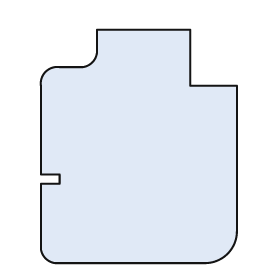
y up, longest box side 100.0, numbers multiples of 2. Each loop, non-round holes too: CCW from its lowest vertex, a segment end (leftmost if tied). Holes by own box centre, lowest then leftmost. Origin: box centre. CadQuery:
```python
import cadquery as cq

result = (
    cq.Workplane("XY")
    .moveTo(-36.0, -50.0)
    .lineTo(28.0, -50.0)
    .threePointArc((38.0, -46.0), (42.0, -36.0))
    .lineTo(42.0, 26.0)
    .lineTo(22.0, 26.0)
    .lineTo(22.0, 50.0)
    .lineTo(-18.0, 50.0)
    .lineTo(-18.0, 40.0)
    .threePointArc((-20.0, 36.0), (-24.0, 34.0))
    .lineTo(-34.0, 34.0)
    .threePointArc((-40.0, 32.0), (-42.0, 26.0))
    .lineTo(-42.0, -12.0)
    .lineTo(-34.0, -12.0)
    .lineTo(-34.0, -16.0)
    .lineTo(-42.0, -16.0)
    .lineTo(-42.0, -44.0)
    .threePointArc((-40.0, -48.0), (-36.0, -50.0))
    .close()
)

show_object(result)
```